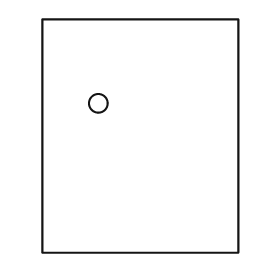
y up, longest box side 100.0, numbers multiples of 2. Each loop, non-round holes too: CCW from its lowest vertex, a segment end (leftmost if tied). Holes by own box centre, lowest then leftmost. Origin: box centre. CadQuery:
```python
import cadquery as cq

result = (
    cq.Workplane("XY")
    .moveTo(-42.0, -50.0)
    .lineTo(42.0, -50.0)
    .lineTo(42.0, 50.0)
    .lineTo(-42.0, 50.0)
    .close()
    .moveTo(-18.0, 14.0)
    .circle(4.0)
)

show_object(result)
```